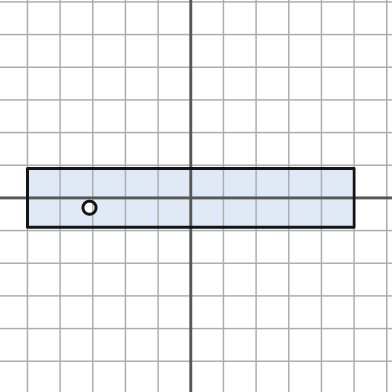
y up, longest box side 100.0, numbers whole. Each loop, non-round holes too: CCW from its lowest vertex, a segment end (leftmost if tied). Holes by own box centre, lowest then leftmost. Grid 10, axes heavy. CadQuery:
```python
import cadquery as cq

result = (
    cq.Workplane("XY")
    .moveTo(-50.0, -9.0)
    .lineTo(50.0, -9.0)
    .lineTo(50.0, 9.0)
    .lineTo(-50.0, 9.0)
    .close()
    .moveTo(-31.0, -3.0)
    .circle(2.0)
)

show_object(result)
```